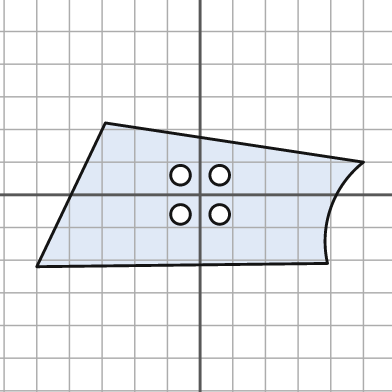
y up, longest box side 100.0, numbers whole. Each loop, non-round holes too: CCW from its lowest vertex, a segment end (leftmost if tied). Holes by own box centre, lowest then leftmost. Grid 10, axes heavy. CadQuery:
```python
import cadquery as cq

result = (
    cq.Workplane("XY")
    .moveTo(-50.0, -22.0)
    .lineTo(39.0, -21.0)
    .threePointArc((40.0, -4.0), (50.0, 10.0))
    .lineTo(-29.0, 22.0)
    .close()
    .moveTo(-6.0, -6.0)
    .circle(3.0)
    .moveTo(6.0, -6.0)
    .circle(3.0)
    .moveTo(-6.0, 6.0)
    .circle(3.0)
    .moveTo(6.0, 6.0)
    .circle(3.0)
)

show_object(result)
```